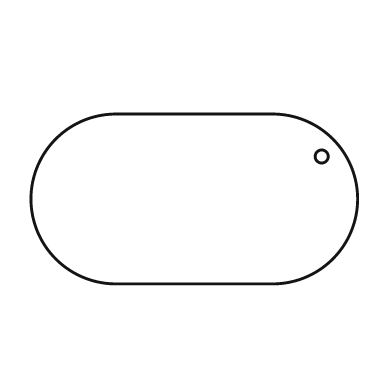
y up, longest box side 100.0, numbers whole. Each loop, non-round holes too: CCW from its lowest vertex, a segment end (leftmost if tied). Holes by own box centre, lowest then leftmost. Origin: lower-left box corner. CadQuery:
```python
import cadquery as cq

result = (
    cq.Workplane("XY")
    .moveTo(26.0, 0.0)
    .lineTo(74.0, 0.0)
    .threePointArc((100.0, 26.0), (74.0, 52.0))
    .lineTo(26.0, 52.0)
    .threePointArc((0.0, 26.0), (26.0, 0.0))
    .close()
    .moveTo(89.0, 39.0)
    .circle(2.0)
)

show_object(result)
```